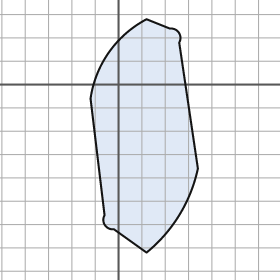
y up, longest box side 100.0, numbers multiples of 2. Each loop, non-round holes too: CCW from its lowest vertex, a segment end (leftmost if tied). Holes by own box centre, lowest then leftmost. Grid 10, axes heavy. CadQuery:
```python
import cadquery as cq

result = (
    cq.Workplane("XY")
    .moveTo(12.0, -72.0)
    .threePointArc((26.0, -56.0), (34.0, -36.0))
    .lineTo(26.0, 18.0)
    .threePointArc((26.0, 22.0), (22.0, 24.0))
    .lineTo(12.0, 28.0)
    .threePointArc((-4.0, 14.0), (-12.0, -6.0))
    .lineTo(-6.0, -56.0)
    .threePointArc((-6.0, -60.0), (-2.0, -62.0))
    .close()
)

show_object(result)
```